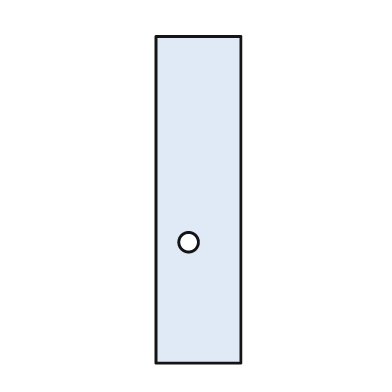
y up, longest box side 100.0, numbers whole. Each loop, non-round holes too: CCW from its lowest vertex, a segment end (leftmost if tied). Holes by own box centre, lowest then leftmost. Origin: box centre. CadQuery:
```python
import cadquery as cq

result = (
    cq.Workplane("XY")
    .moveTo(-13.0, -50.0)
    .lineTo(13.0, -50.0)
    .lineTo(13.0, 50.0)
    .lineTo(-13.0, 50.0)
    .close()
    .moveTo(-3.0, -13.0)
    .circle(3.0)
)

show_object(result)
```